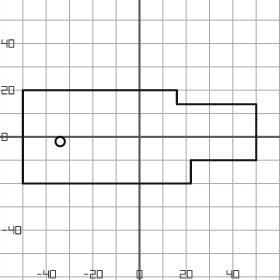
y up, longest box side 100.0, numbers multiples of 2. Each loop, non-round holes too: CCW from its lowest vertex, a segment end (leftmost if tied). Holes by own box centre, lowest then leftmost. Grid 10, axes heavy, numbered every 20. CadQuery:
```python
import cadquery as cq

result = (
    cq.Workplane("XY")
    .moveTo(-50.0, -20.0)
    .lineTo(22.0, -20.0)
    .lineTo(22.0, -10.0)
    .lineTo(50.0, -10.0)
    .lineTo(50.0, 14.0)
    .lineTo(16.0, 14.0)
    .lineTo(16.0, 20.0)
    .lineTo(-50.0, 20.0)
    .close()
    .moveTo(-34.0, -2.0)
    .circle(2.0)
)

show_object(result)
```